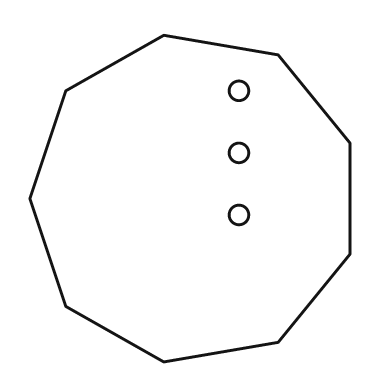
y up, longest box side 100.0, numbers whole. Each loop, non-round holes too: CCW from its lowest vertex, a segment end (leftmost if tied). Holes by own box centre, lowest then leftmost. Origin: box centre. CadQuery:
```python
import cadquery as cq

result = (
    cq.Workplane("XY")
    .moveTo(-8.0, -50.0)
    .lineTo(27.0, -44.0)
    .lineTo(49.0, -17.0)
    .lineTo(49.0, 17.0)
    .lineTo(27.0, 44.0)
    .lineTo(-8.0, 50.0)
    .lineTo(-38.0, 33.0)
    .lineTo(-49.0, 0.0)
    .lineTo(-38.0, -33.0)
    .close()
    .moveTo(15.0, -5.0)
    .circle(3.0)
    .moveTo(15.0, 14.0)
    .circle(3.0)
    .moveTo(15.0, 33.0)
    .circle(3.0)
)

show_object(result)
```